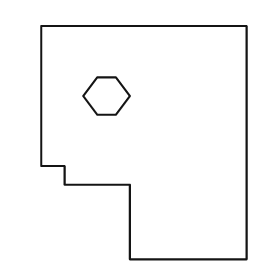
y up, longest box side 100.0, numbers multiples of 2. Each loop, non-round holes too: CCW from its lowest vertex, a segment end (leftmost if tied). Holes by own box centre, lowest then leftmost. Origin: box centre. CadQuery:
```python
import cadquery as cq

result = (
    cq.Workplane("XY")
    .moveTo(-6.0, -50.0)
    .lineTo(44.0, -50.0)
    .lineTo(44.0, 50.0)
    .lineTo(-44.0, 50.0)
    .lineTo(-44.0, -10.0)
    .lineTo(-34.0, -10.0)
    .lineTo(-34.0, -18.0)
    .lineTo(-6.0, -18.0)
    .close()
    .moveTo(-20.0, 12.0)
    .lineTo(-12.0, 12.0)
    .lineTo(-6.0, 20.0)
    .lineTo(-12.0, 28.0)
    .lineTo(-20.0, 28.0)
    .lineTo(-26.0, 20.0)
    .close()
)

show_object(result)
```